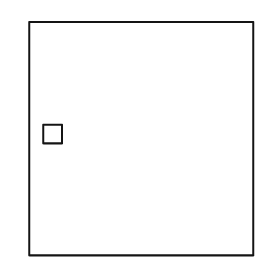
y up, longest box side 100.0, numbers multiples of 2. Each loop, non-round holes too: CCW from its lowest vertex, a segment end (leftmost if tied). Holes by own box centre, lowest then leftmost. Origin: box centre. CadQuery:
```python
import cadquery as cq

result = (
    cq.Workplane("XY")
    .moveTo(-48.0, -50.0)
    .lineTo(48.0, -50.0)
    .lineTo(48.0, 50.0)
    .lineTo(-48.0, 50.0)
    .close()
    .moveTo(-42.0, -2.0)
    .lineTo(-34.0, -2.0)
    .lineTo(-34.0, 6.0)
    .lineTo(-42.0, 6.0)
    .close()
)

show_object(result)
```